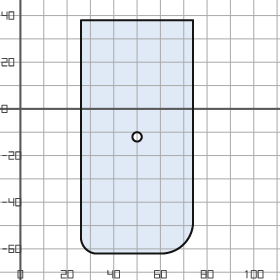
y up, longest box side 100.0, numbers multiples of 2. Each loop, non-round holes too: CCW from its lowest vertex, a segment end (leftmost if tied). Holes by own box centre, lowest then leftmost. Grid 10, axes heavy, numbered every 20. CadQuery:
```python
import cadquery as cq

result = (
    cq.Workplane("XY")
    .moveTo(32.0, -62.0)
    .lineTo(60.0, -62.0)
    .threePointArc((70.0, -58.0), (74.0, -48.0))
    .lineTo(74.0, 38.0)
    .lineTo(26.0, 38.0)
    .lineTo(26.0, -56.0)
    .threePointArc((28.0, -60.0), (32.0, -62.0))
    .close()
    .moveTo(50.0, -12.0)
    .circle(2.0)
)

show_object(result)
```